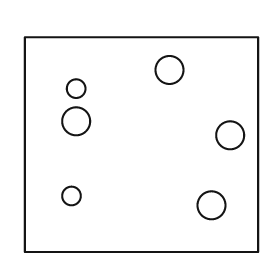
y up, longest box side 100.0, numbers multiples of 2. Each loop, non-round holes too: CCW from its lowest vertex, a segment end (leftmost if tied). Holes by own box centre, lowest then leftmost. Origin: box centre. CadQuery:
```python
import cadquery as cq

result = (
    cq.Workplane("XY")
    .moveTo(-50.0, -46.0)
    .lineTo(50.0, -46.0)
    .lineTo(50.0, 46.0)
    .lineTo(-50.0, 46.0)
    .close()
    .moveTo(30.0, -26.0)
    .circle(6.0)
    .moveTo(-30.0, -22.0)
    .circle(4.0)
    .moveTo(38.0, 4.0)
    .circle(6.0)
    .moveTo(-28.0, 10.0)
    .circle(6.0)
    .moveTo(-28.0, 24.0)
    .circle(4.0)
    .moveTo(12.0, 32.0)
    .circle(6.0)
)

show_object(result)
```